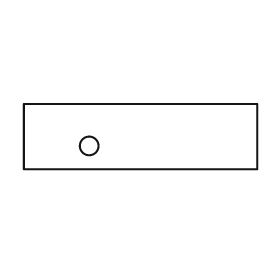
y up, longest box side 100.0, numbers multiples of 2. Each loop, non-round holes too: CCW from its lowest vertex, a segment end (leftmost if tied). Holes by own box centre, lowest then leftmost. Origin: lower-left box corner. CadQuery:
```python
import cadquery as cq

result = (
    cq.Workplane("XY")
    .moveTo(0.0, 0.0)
    .lineTo(100.0, 0.0)
    .lineTo(100.0, 28.0)
    .lineTo(0.0, 28.0)
    .close()
    .moveTo(28.0, 10.0)
    .circle(4.0)
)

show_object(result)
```